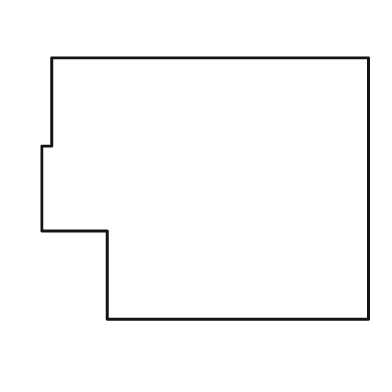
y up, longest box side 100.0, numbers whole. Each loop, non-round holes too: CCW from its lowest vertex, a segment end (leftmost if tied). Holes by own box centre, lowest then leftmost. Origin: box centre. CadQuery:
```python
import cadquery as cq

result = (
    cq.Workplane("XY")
    .moveTo(-30.0, -40.0)
    .lineTo(50.0, -40.0)
    .lineTo(50.0, 40.0)
    .lineTo(-47.0, 40.0)
    .lineTo(-47.0, 13.0)
    .lineTo(-50.0, 13.0)
    .lineTo(-50.0, -13.0)
    .lineTo(-30.0, -13.0)
    .close()
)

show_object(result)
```